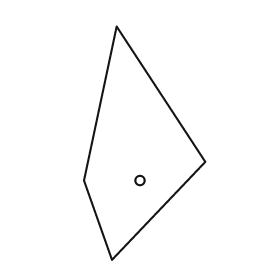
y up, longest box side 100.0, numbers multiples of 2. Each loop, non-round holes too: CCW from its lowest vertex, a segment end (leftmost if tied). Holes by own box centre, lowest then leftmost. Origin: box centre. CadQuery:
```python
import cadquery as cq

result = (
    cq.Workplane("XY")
    .moveTo(-14.0, -50.0)
    .lineTo(26.0, -8.0)
    .lineTo(-12.0, 50.0)
    .lineTo(-26.0, -16.0)
    .close()
    .moveTo(-2.0, -16.0)
    .circle(2.0)
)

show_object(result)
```